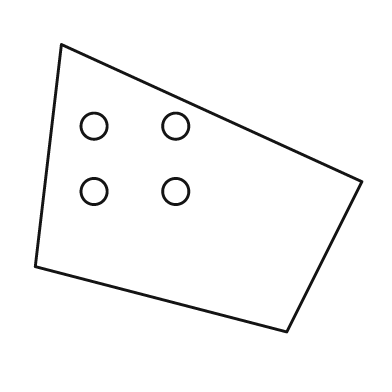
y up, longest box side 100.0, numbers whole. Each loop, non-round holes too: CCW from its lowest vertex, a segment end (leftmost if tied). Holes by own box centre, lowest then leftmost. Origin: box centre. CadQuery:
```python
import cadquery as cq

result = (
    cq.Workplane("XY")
    .moveTo(27.0, -44.0)
    .lineTo(50.0, 2.0)
    .lineTo(-42.0, 44.0)
    .lineTo(-50.0, -24.0)
    .close()
    .moveTo(-32.0, -1.0)
    .circle(4.0)
    .moveTo(-7.0, -1.0)
    .circle(4.0)
    .moveTo(-32.0, 19.0)
    .circle(4.0)
    .moveTo(-7.0, 19.0)
    .circle(4.0)
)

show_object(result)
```